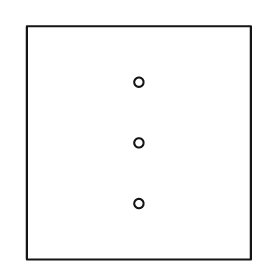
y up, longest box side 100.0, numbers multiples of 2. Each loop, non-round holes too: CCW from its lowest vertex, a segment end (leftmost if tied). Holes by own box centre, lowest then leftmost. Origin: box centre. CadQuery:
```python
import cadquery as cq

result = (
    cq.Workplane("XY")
    .moveTo(-48.0, -50.0)
    .lineTo(48.0, -50.0)
    .lineTo(48.0, 50.0)
    .lineTo(-48.0, 50.0)
    .close()
    .moveTo(0.0, -26.0)
    .circle(2.0)
    .moveTo(0.0, 0.0)
    .circle(2.0)
    .moveTo(0.0, 26.0)
    .circle(2.0)
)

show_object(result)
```